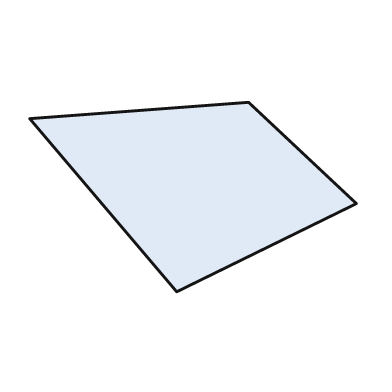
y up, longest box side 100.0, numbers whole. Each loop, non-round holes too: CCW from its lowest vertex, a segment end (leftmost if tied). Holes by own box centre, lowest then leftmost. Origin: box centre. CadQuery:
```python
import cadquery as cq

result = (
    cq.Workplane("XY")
    .moveTo(-5.0, -29.0)
    .lineTo(50.0, -2.0)
    .lineTo(17.0, 29.0)
    .lineTo(-50.0, 24.0)
    .close()
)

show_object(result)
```